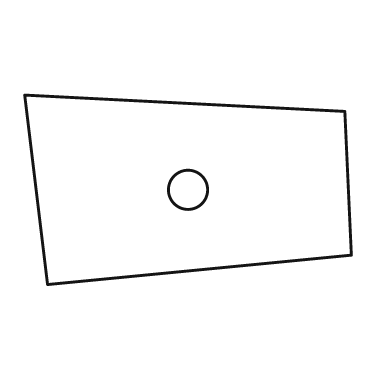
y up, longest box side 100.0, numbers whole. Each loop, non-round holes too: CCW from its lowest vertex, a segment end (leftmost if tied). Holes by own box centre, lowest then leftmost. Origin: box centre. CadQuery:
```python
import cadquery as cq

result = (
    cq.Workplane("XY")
    .moveTo(-43.0, -29.0)
    .lineTo(50.0, -20.0)
    .lineTo(48.0, 24.0)
    .lineTo(-50.0, 29.0)
    .close()
    .moveTo(0.0, 0.0)
    .circle(6.0)
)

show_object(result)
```